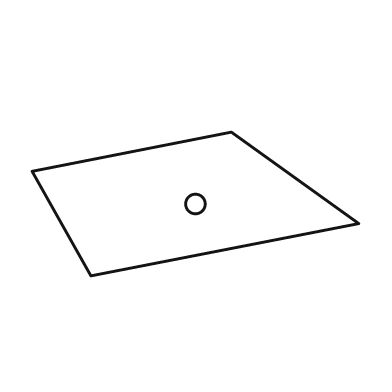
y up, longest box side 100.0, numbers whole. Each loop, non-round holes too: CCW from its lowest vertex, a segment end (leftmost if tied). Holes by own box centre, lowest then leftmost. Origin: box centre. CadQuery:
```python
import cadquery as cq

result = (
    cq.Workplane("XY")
    .moveTo(-32.0, -22.0)
    .lineTo(50.0, -6.0)
    .lineTo(11.0, 22.0)
    .lineTo(-50.0, 10.0)
    .close()
    .moveTo(0.0, 0.0)
    .circle(3.0)
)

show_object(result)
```